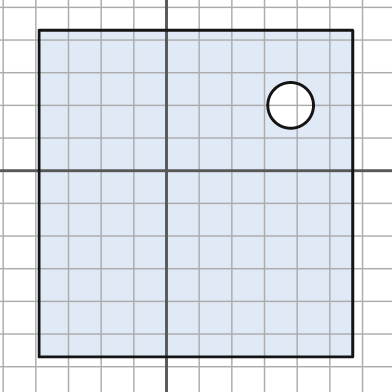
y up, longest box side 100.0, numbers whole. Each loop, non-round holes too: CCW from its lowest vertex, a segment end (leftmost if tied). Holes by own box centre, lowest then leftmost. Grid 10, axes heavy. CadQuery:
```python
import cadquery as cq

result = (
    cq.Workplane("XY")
    .moveTo(-39.0, -57.0)
    .lineTo(57.0, -57.0)
    .lineTo(57.0, 43.0)
    .lineTo(-39.0, 43.0)
    .close()
    .moveTo(38.0, 20.0)
    .circle(7.0)
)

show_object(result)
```